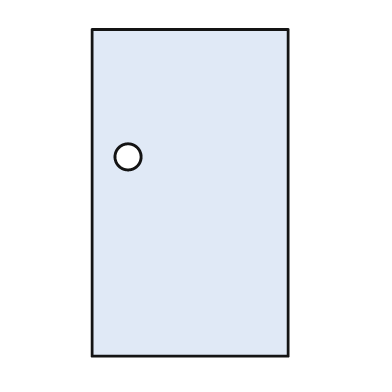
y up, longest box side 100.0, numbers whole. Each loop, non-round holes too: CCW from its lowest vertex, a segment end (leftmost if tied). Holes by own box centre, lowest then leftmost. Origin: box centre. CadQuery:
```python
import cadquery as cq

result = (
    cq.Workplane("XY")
    .moveTo(-30.0, -50.0)
    .lineTo(30.0, -50.0)
    .lineTo(30.0, 50.0)
    .lineTo(-30.0, 50.0)
    .close()
    .moveTo(-19.0, 11.0)
    .circle(4.0)
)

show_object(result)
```